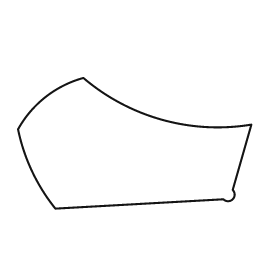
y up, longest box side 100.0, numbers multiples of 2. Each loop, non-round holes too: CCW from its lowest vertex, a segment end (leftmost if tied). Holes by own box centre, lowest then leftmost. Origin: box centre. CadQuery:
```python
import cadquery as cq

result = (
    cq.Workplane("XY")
    .moveTo(-34.0, -28.0)
    .lineTo(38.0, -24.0)
    .threePointArc((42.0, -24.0), (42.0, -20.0))
    .lineTo(50.0, 8.0)
    .threePointArc((12.0, 10.0), (-22.0, 28.0))
    .threePointArc((-38.0, 20.0), (-50.0, 6.0))
    .threePointArc((-44.0, -12.0), (-34.0, -28.0))
    .close()
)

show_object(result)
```